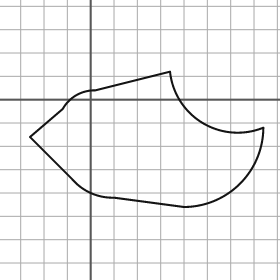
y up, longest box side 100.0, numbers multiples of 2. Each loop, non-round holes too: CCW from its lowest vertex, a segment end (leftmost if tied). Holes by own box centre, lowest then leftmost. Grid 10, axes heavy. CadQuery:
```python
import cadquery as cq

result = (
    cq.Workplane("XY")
    .moveTo(40.0, -46.0)
    .threePointArc((64.0, -36.0), (74.0, -12.0))
    .threePointArc((48.0, -10.0), (34.0, 12.0))
    .lineTo(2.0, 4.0)
    .threePointArc((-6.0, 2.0), (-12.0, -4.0))
    .lineTo(-26.0, -16.0)
    .lineTo(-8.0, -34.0)
    .threePointArc((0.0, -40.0), (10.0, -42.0))
    .close()
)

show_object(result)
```